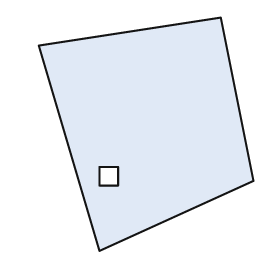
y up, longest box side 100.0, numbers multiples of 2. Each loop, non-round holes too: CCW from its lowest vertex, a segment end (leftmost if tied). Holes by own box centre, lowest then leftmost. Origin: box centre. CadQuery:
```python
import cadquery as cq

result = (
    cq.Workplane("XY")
    .moveTo(-20.0, -50.0)
    .lineTo(46.0, -20.0)
    .lineTo(32.0, 50.0)
    .lineTo(-46.0, 38.0)
    .close()
    .moveTo(-20.0, -22.0)
    .lineTo(-12.0, -22.0)
    .lineTo(-12.0, -14.0)
    .lineTo(-20.0, -14.0)
    .close()
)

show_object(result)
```